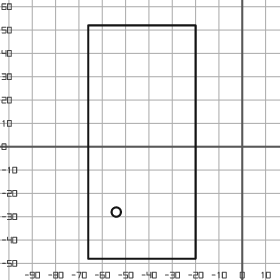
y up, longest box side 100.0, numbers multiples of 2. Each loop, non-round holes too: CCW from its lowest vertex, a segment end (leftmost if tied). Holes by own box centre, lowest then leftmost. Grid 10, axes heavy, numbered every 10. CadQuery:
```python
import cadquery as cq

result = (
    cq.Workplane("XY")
    .moveTo(-66.0, -48.0)
    .lineTo(-20.0, -48.0)
    .lineTo(-20.0, 52.0)
    .lineTo(-66.0, 52.0)
    .close()
    .moveTo(-54.0, -28.0)
    .circle(2.0)
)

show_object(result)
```